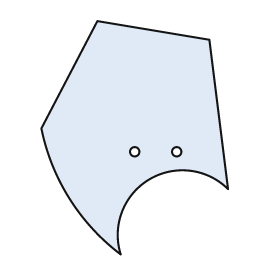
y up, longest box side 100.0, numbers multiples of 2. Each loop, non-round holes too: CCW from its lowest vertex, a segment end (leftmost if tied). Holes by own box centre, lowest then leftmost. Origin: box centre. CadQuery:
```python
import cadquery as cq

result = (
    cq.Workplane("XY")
    .moveTo(-6.0, -50.0)
    .threePointArc((6.0, -18.0), (40.0, -22.0))
    .lineTo(32.0, 42.0)
    .lineTo(-16.0, 50.0)
    .lineTo(-40.0, 4.0)
    .threePointArc((-28.0, -26.0), (-6.0, -50.0))
    .close()
    .moveTo(0.0, -6.0)
    .circle(2.0)
    .moveTo(18.0, -6.0)
    .circle(2.0)
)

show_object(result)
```